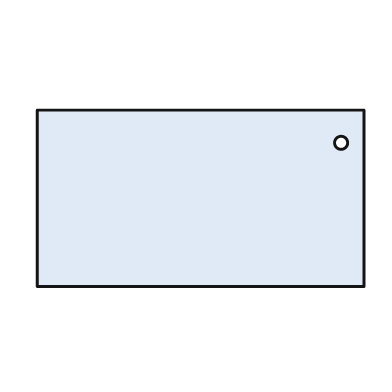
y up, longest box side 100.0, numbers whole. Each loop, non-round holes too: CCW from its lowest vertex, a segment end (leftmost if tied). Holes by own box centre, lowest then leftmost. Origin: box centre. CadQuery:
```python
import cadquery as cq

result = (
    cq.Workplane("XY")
    .moveTo(-50.0, -27.0)
    .lineTo(50.0, -27.0)
    .lineTo(50.0, 27.0)
    .lineTo(-50.0, 27.0)
    .close()
    .moveTo(43.0, 17.0)
    .circle(2.0)
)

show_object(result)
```